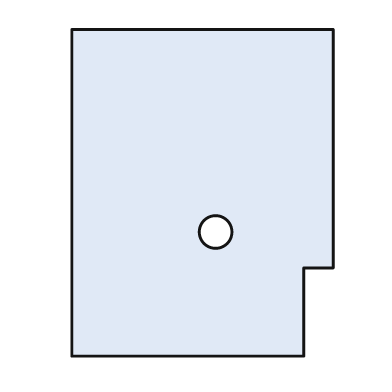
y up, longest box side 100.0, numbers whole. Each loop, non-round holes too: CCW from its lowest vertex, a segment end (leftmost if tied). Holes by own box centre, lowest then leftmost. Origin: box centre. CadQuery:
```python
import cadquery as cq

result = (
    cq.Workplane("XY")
    .moveTo(-40.0, -50.0)
    .lineTo(31.0, -50.0)
    .lineTo(31.0, -23.0)
    .lineTo(40.0, -23.0)
    .lineTo(40.0, 50.0)
    .lineTo(-40.0, 50.0)
    .close()
    .moveTo(4.0, -12.0)
    .circle(5.0)
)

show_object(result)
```